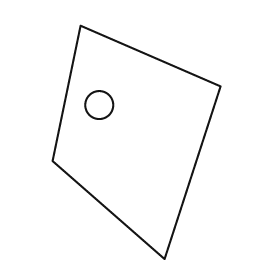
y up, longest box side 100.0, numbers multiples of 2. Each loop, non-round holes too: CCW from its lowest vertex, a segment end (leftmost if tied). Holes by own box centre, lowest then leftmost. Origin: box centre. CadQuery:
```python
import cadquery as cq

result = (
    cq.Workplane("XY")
    .moveTo(12.0, -50.0)
    .lineTo(36.0, 24.0)
    .lineTo(-24.0, 50.0)
    .lineTo(-36.0, -8.0)
    .close()
    .moveTo(-16.0, 16.0)
    .circle(6.0)
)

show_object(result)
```